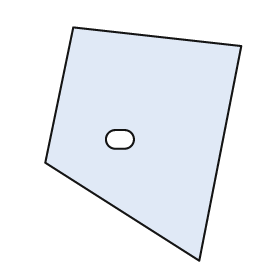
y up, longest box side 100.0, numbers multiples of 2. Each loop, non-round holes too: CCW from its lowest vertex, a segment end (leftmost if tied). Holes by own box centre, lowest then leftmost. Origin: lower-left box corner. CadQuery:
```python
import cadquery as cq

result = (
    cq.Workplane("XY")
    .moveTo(66.0, 0.0)
    .lineTo(84.0, 92.0)
    .lineTo(12.0, 100.0)
    .lineTo(0.0, 42.0)
    .close()
    .moveTo(30.0, 48.0)
    .lineTo(34.0, 48.0)
    .threePointArc((38.0, 52.0), (34.0, 56.0))
    .lineTo(30.0, 56.0)
    .threePointArc((26.0, 52.0), (30.0, 48.0))
    .close()
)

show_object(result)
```